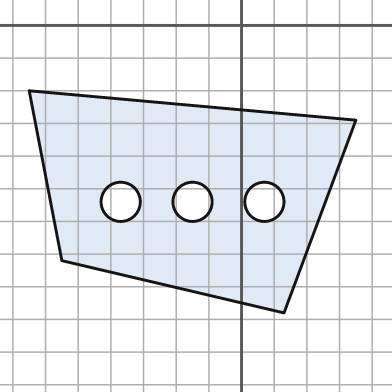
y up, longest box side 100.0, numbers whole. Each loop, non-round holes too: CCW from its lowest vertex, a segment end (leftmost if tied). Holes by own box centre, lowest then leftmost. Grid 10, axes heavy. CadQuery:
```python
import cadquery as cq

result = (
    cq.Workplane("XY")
    .moveTo(13.0, -88.0)
    .lineTo(35.0, -29.0)
    .lineTo(-65.0, -20.0)
    .lineTo(-55.0, -72.0)
    .close()
    .moveTo(-37.0, -54.0)
    .circle(6.0)
    .moveTo(-15.0, -54.0)
    .circle(6.0)
    .moveTo(7.0, -54.0)
    .circle(6.0)
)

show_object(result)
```